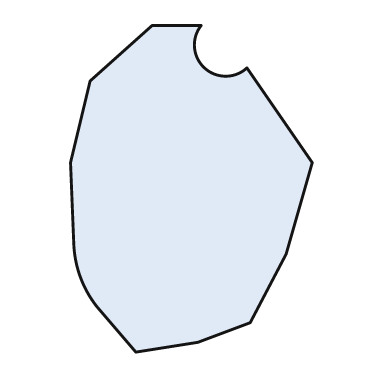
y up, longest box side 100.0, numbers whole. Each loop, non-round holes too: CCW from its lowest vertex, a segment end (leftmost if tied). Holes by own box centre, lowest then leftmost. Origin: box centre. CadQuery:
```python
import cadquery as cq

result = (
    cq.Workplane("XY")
    .moveTo(-17.0, -50.0)
    .lineTo(2.0, -47.0)
    .lineTo(18.0, -41.0)
    .lineTo(29.0, -20.0)
    .lineTo(37.0, 8.0)
    .lineTo(17.0, 37.0)
    .threePointArc((4.0, 37.0), (3.0, 50.0))
    .lineTo(-12.0, 50.0)
    .lineTo(-31.0, 33.0)
    .lineTo(-37.0, 8.0)
    .lineTo(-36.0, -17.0)
    .threePointArc((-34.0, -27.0), (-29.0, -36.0))
    .close()
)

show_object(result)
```